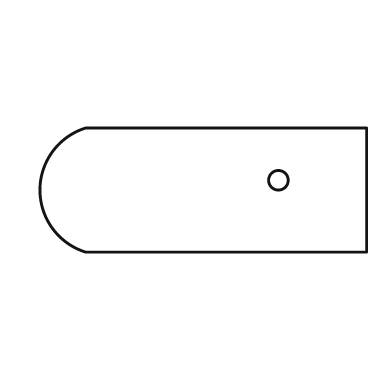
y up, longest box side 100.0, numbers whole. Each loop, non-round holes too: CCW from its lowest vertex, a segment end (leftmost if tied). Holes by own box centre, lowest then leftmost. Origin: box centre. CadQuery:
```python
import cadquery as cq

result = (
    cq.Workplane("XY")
    .moveTo(-36.0, -19.0)
    .lineTo(50.0, -19.0)
    .lineTo(50.0, 19.0)
    .lineTo(-36.0, 19.0)
    .threePointArc((-50.0, 0.0), (-36.0, -19.0))
    .close()
    .moveTo(23.0, 3.0)
    .circle(3.0)
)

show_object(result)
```